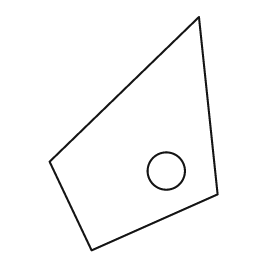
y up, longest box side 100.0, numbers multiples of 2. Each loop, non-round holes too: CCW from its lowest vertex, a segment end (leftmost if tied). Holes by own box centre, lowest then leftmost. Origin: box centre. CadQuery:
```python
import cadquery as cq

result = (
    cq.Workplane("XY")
    .moveTo(-18.0, -50.0)
    .lineTo(36.0, -26.0)
    .lineTo(28.0, 50.0)
    .lineTo(-36.0, -12.0)
    .close()
    .moveTo(14.0, -16.0)
    .circle(8.0)
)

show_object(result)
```